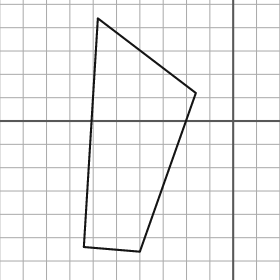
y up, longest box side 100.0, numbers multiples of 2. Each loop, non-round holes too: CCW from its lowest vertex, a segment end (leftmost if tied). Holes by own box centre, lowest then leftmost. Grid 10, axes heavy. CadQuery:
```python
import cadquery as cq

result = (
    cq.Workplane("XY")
    .moveTo(-40.0, -56.0)
    .lineTo(-16.0, 12.0)
    .lineTo(-58.0, 44.0)
    .lineTo(-64.0, -54.0)
    .close()
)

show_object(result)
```